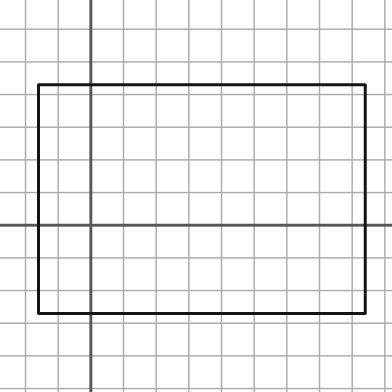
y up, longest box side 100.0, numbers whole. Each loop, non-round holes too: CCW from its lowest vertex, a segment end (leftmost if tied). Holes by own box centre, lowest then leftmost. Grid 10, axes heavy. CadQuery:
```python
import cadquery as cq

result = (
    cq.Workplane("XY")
    .moveTo(-16.0, -27.0)
    .lineTo(84.0, -27.0)
    .lineTo(84.0, 43.0)
    .lineTo(-16.0, 43.0)
    .close()
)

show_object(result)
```